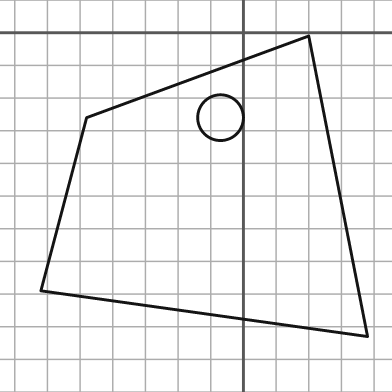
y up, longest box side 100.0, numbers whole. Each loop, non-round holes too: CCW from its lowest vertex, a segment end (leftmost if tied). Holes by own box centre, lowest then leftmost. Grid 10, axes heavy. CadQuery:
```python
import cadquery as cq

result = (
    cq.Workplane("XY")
    .moveTo(38.0, -93.0)
    .lineTo(20.0, -1.0)
    .lineTo(-48.0, -26.0)
    .lineTo(-62.0, -79.0)
    .close()
    .moveTo(-7.0, -26.0)
    .circle(7.0)
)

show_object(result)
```